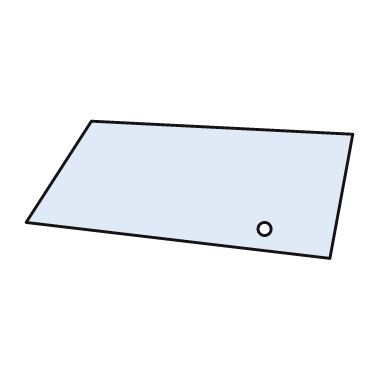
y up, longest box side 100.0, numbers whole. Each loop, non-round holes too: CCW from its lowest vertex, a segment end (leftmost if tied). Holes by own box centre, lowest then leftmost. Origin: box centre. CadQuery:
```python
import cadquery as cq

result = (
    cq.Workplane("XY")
    .moveTo(43.0, -21.0)
    .lineTo(50.0, 17.0)
    .lineTo(-30.0, 21.0)
    .lineTo(-50.0, -10.0)
    .close()
    .moveTo(23.0, -12.0)
    .circle(2.0)
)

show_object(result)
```